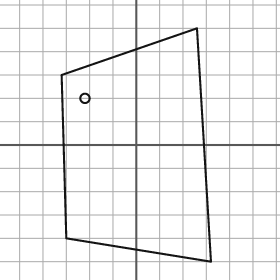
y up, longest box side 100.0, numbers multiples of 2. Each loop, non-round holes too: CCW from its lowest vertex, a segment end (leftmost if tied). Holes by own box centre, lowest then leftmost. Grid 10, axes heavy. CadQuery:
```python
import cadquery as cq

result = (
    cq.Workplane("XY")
    .moveTo(32.0, -50.0)
    .lineTo(26.0, 50.0)
    .lineTo(-32.0, 30.0)
    .lineTo(-30.0, -40.0)
    .close()
    .moveTo(-22.0, 20.0)
    .circle(2.0)
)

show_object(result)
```